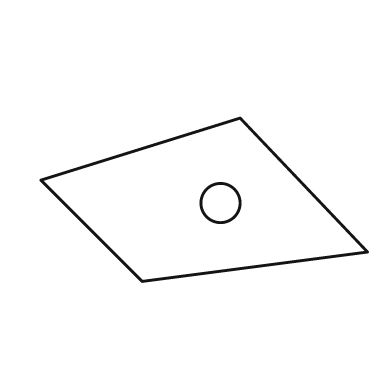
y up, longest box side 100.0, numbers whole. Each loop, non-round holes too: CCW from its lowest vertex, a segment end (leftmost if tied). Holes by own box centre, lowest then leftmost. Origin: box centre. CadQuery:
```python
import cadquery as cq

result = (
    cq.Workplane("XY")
    .moveTo(-19.0, -25.0)
    .lineTo(50.0, -16.0)
    .lineTo(11.0, 25.0)
    .lineTo(-50.0, 6.0)
    .close()
    .moveTo(5.0, -1.0)
    .circle(6.0)
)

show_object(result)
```